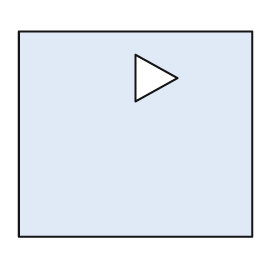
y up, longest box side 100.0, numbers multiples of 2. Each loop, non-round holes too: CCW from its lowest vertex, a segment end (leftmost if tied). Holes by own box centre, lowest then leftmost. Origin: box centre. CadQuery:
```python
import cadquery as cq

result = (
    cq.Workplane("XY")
    .moveTo(-50.0, -44.0)
    .lineTo(50.0, -44.0)
    .lineTo(50.0, 44.0)
    .lineTo(-50.0, 44.0)
    .close()
    .moveTo(0.0, 14.0)
    .lineTo(18.0, 24.0)
    .lineTo(0.0, 34.0)
    .close()
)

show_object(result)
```